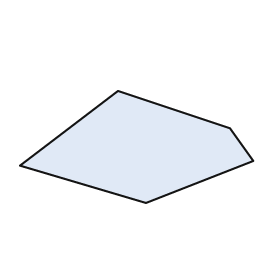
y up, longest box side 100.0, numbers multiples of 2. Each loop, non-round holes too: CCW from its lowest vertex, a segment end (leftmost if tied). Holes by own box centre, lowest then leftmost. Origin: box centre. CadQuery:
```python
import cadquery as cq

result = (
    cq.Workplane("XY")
    .moveTo(4.0, -24.0)
    .lineTo(50.0, -6.0)
    .lineTo(40.0, 8.0)
    .lineTo(-8.0, 24.0)
    .lineTo(-50.0, -8.0)
    .close()
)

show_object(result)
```